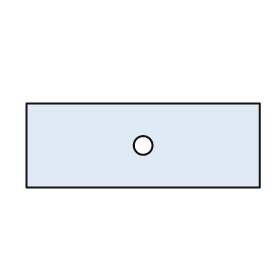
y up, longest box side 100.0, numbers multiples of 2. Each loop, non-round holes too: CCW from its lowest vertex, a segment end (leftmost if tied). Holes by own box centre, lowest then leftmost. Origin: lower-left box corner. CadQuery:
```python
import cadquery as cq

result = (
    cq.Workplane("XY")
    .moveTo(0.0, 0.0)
    .lineTo(100.0, 0.0)
    .lineTo(100.0, 36.0)
    .lineTo(0.0, 36.0)
    .close()
    .moveTo(50.0, 18.0)
    .circle(4.0)
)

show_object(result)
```